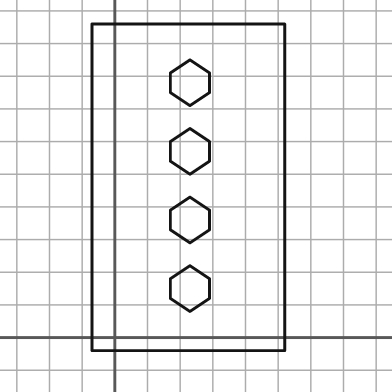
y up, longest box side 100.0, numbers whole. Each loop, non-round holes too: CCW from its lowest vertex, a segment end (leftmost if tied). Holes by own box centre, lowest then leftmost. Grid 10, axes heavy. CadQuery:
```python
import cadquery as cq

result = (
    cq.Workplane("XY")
    .moveTo(-7.0, -4.0)
    .lineTo(52.0, -4.0)
    .lineTo(52.0, 96.0)
    .lineTo(-7.0, 96.0)
    .close()
    .moveTo(23.0, 8.0)
    .lineTo(29.0, 12.0)
    .lineTo(29.0, 18.0)
    .lineTo(23.0, 22.0)
    .lineTo(17.0, 18.0)
    .lineTo(17.0, 12.0)
    .close()
    .moveTo(23.0, 29.0)
    .lineTo(29.0, 33.0)
    .lineTo(29.0, 39.0)
    .lineTo(23.0, 43.0)
    .lineTo(17.0, 39.0)
    .lineTo(17.0, 33.0)
    .close()
    .moveTo(23.0, 50.0)
    .lineTo(29.0, 54.0)
    .lineTo(29.0, 60.0)
    .lineTo(23.0, 64.0)
    .lineTo(17.0, 60.0)
    .lineTo(17.0, 54.0)
    .close()
    .moveTo(23.0, 71.0)
    .lineTo(29.0, 75.0)
    .lineTo(29.0, 81.0)
    .lineTo(23.0, 85.0)
    .lineTo(17.0, 81.0)
    .lineTo(17.0, 75.0)
    .close()
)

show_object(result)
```